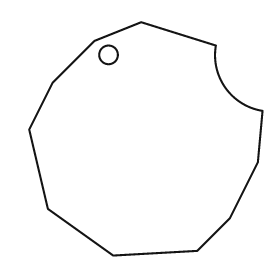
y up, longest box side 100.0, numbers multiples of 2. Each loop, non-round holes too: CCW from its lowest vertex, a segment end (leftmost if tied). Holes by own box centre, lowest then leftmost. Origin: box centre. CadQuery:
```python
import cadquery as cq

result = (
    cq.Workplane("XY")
    .moveTo(-14.0, -50.0)
    .lineTo(22.0, -48.0)
    .lineTo(36.0, -34.0)
    .lineTo(48.0, -10.0)
    .lineTo(50.0, 12.0)
    .threePointArc((34.0, 22.0), (30.0, 40.0))
    .lineTo(-2.0, 50.0)
    .lineTo(-22.0, 42.0)
    .lineTo(-40.0, 24.0)
    .lineTo(-50.0, 4.0)
    .lineTo(-42.0, -30.0)
    .close()
    .moveTo(-16.0, 36.0)
    .circle(4.0)
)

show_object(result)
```